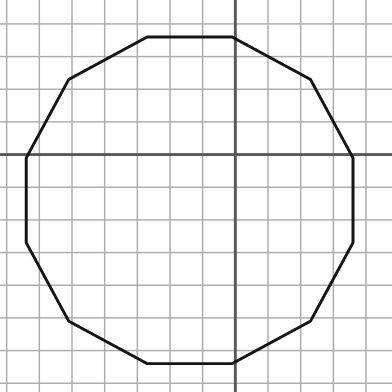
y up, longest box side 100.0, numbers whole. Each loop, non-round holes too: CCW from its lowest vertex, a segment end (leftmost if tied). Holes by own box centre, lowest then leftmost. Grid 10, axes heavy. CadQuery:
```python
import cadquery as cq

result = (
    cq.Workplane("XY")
    .moveTo(-27.0, -64.0)
    .lineTo(-1.0, -64.0)
    .lineTo(23.0, -51.0)
    .lineTo(36.0, -27.0)
    .lineTo(36.0, -1.0)
    .lineTo(23.0, 23.0)
    .lineTo(-1.0, 36.0)
    .lineTo(-27.0, 36.0)
    .lineTo(-51.0, 23.0)
    .lineTo(-64.0, -1.0)
    .lineTo(-64.0, -27.0)
    .lineTo(-51.0, -51.0)
    .close()
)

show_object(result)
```